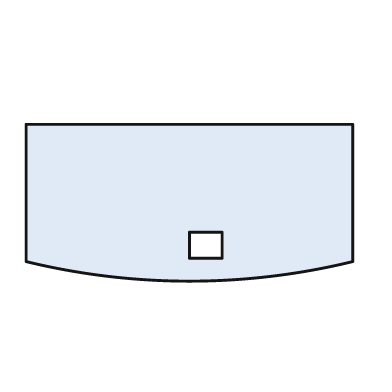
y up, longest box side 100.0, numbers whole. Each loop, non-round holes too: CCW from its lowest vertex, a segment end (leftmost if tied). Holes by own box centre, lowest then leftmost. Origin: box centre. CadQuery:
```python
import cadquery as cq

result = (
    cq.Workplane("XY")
    .moveTo(-50.0, -18.0)
    .threePointArc((0.0, -24.0), (50.0, -18.0))
    .lineTo(50.0, 24.0)
    .lineTo(-50.0, 24.0)
    .close()
    .moveTo(0.0, -17.0)
    .lineTo(10.0, -17.0)
    .lineTo(10.0, -9.0)
    .lineTo(0.0, -9.0)
    .close()
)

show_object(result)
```